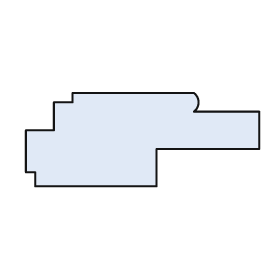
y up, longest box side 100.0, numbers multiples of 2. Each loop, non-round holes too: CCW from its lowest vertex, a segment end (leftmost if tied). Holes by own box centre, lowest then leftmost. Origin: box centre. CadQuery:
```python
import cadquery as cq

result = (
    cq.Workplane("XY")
    .moveTo(-46.0, -20.0)
    .lineTo(6.0, -20.0)
    .lineTo(6.0, -4.0)
    .lineTo(50.0, -4.0)
    .lineTo(50.0, 12.0)
    .lineTo(22.0, 12.0)
    .threePointArc((24.0, 16.0), (22.0, 20.0))
    .lineTo(-30.0, 20.0)
    .lineTo(-30.0, 16.0)
    .lineTo(-38.0, 16.0)
    .lineTo(-38.0, 4.0)
    .lineTo(-50.0, 4.0)
    .lineTo(-50.0, -14.0)
    .lineTo(-46.0, -14.0)
    .close()
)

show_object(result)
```